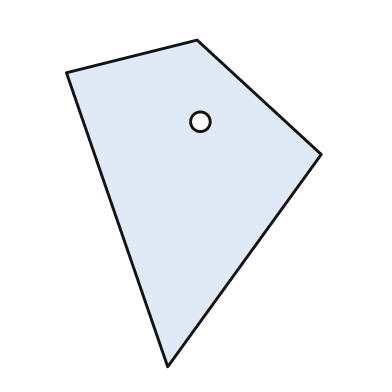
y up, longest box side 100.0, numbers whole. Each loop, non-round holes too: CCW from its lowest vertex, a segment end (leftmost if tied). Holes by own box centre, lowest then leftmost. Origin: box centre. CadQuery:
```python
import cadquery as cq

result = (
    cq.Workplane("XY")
    .moveTo(-8.0, -50.0)
    .lineTo(39.0, 15.0)
    .lineTo(1.0, 50.0)
    .lineTo(-39.0, 40.0)
    .close()
    .moveTo(2.0, 25.0)
    .circle(3.0)
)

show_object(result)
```